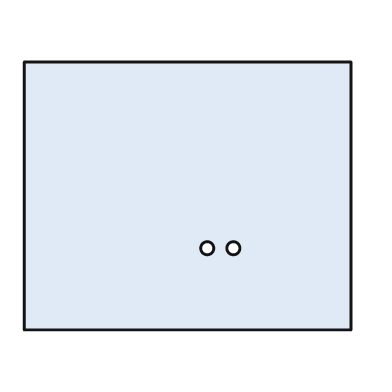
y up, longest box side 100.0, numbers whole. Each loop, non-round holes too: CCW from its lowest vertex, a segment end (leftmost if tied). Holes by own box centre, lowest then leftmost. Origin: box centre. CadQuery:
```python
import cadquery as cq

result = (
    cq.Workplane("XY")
    .moveTo(-50.0, -41.0)
    .lineTo(50.0, -41.0)
    .lineTo(50.0, 41.0)
    .lineTo(-50.0, 41.0)
    .close()
    .moveTo(6.0, -16.0)
    .circle(2.0)
    .moveTo(14.0, -16.0)
    .circle(2.0)
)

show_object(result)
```